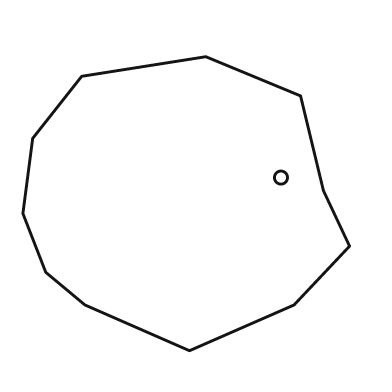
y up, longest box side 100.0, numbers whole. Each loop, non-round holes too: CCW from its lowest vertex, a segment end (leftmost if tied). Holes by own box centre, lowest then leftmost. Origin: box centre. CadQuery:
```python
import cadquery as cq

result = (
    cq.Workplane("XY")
    .moveTo(1.0, -45.0)
    .lineTo(33.0, -31.0)
    .lineTo(50.0, -13.0)
    .lineTo(42.0, 4.0)
    .lineTo(35.0, 33.0)
    .lineTo(6.0, 45.0)
    .lineTo(-32.0, 39.0)
    .lineTo(-47.0, 20.0)
    .lineTo(-50.0, -3.0)
    .lineTo(-43.0, -21.0)
    .lineTo(-31.0, -31.0)
    .close()
    .moveTo(29.0, 8.0)
    .circle(2.0)
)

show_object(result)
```